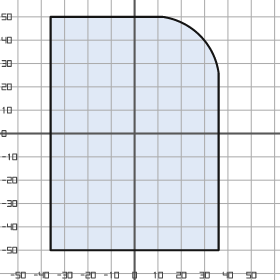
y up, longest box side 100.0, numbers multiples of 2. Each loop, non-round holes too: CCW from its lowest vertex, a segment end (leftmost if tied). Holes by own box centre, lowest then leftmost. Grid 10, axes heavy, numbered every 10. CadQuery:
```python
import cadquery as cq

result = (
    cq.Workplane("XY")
    .moveTo(-36.0, -50.0)
    .lineTo(36.0, -50.0)
    .lineTo(36.0, 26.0)
    .threePointArc((28.0, 42.0), (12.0, 50.0))
    .lineTo(-36.0, 50.0)
    .close()
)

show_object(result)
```